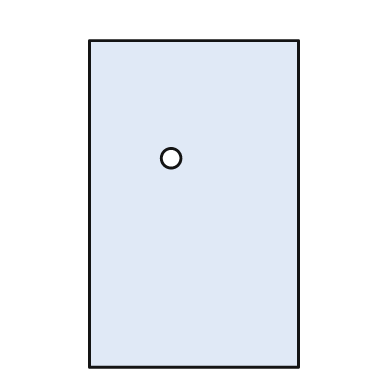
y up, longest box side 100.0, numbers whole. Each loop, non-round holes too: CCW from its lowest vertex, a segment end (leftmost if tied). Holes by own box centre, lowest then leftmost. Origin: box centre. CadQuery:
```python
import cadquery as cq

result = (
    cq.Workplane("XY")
    .moveTo(-32.0, -50.0)
    .lineTo(32.0, -50.0)
    .lineTo(32.0, 50.0)
    .lineTo(-32.0, 50.0)
    .close()
    .moveTo(-7.0, 14.0)
    .circle(3.0)
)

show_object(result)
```